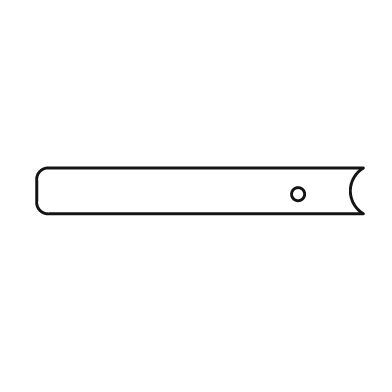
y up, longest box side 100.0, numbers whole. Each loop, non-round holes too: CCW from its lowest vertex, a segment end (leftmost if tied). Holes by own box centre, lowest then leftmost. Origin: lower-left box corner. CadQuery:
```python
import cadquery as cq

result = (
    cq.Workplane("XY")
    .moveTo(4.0, 0.0)
    .lineTo(100.0, 0.0)
    .threePointArc((96.0, 7.0), (100.0, 14.0))
    .lineTo(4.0, 14.0)
    .threePointArc((1.0, 13.0), (0.0, 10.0))
    .lineTo(0.0, 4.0)
    .threePointArc((1.0, 1.0), (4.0, 0.0))
    .close()
    .moveTo(80.0, 6.0)
    .circle(2.0)
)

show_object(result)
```